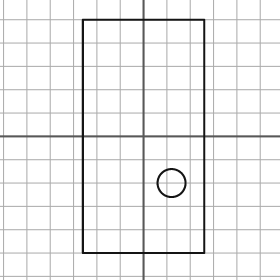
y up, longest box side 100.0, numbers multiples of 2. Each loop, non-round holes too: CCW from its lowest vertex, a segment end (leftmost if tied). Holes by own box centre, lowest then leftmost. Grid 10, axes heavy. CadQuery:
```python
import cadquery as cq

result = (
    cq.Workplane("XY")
    .moveTo(-26.0, -50.0)
    .lineTo(26.0, -50.0)
    .lineTo(26.0, 50.0)
    .lineTo(-26.0, 50.0)
    .close()
    .moveTo(12.0, -20.0)
    .circle(6.0)
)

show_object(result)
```